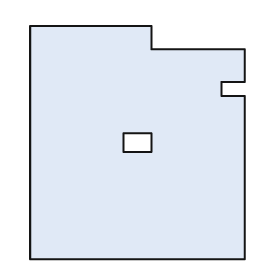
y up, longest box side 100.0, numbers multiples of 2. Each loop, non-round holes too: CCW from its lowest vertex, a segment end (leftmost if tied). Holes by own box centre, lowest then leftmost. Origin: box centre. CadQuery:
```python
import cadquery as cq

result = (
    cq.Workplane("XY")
    .moveTo(-46.0, -50.0)
    .lineTo(46.0, -50.0)
    .lineTo(46.0, 20.0)
    .lineTo(36.0, 20.0)
    .lineTo(36.0, 26.0)
    .lineTo(46.0, 26.0)
    .lineTo(46.0, 40.0)
    .lineTo(6.0, 40.0)
    .lineTo(6.0, 50.0)
    .lineTo(-46.0, 50.0)
    .close()
    .moveTo(-6.0, -4.0)
    .lineTo(6.0, -4.0)
    .lineTo(6.0, 4.0)
    .lineTo(-6.0, 4.0)
    .close()
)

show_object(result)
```